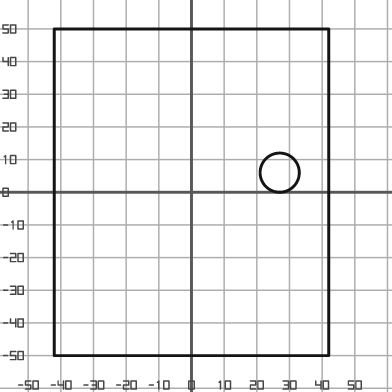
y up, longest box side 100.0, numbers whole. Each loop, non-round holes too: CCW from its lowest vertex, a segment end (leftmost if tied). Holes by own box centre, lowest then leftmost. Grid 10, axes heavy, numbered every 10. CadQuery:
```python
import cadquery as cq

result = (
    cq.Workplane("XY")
    .moveTo(-42.0, -50.0)
    .lineTo(42.0, -50.0)
    .lineTo(42.0, 50.0)
    .lineTo(-42.0, 50.0)
    .close()
    .moveTo(27.0, 6.0)
    .circle(6.0)
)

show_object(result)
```